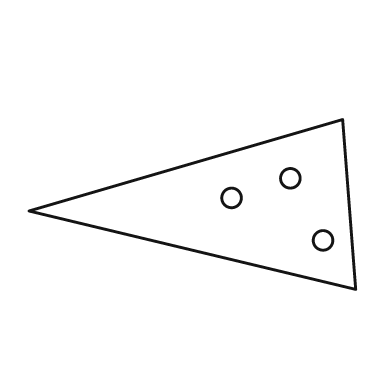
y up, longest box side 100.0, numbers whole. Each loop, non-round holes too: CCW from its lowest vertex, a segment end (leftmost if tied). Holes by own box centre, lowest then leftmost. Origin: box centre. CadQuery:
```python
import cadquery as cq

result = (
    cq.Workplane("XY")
    .moveTo(50.0, -26.0)
    .lineTo(46.0, 26.0)
    .lineTo(-50.0, -2.0)
    .close()
    .moveTo(40.0, -11.0)
    .circle(3.0)
    .moveTo(12.0, 2.0)
    .circle(3.0)
    .moveTo(30.0, 8.0)
    .circle(3.0)
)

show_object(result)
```